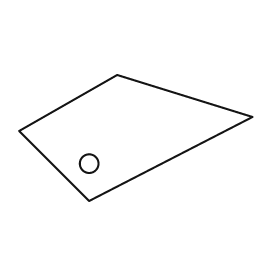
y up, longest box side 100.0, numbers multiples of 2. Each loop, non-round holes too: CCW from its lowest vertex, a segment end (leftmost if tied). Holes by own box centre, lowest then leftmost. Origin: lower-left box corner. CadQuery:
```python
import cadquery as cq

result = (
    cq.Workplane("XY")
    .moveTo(30.0, 0.0)
    .lineTo(100.0, 36.0)
    .lineTo(42.0, 54.0)
    .lineTo(0.0, 30.0)
    .close()
    .moveTo(30.0, 16.0)
    .circle(4.0)
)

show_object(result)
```